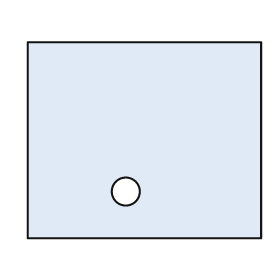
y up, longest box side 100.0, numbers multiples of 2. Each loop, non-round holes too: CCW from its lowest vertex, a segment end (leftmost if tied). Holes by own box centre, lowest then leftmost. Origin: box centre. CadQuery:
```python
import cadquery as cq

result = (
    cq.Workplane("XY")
    .moveTo(-50.0, -42.0)
    .lineTo(50.0, -42.0)
    .lineTo(50.0, 42.0)
    .lineTo(-50.0, 42.0)
    .close()
    .moveTo(-8.0, -22.0)
    .circle(6.0)
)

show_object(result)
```